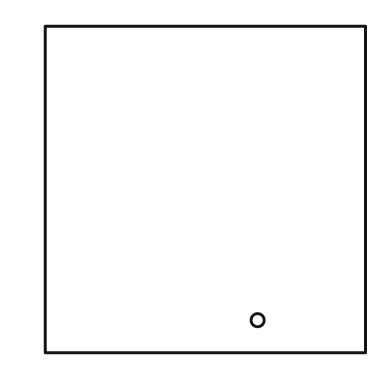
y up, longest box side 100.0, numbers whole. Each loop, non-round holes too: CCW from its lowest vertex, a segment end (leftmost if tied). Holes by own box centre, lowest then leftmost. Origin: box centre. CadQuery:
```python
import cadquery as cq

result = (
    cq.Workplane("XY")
    .moveTo(-49.0, -50.0)
    .lineTo(49.0, -50.0)
    .lineTo(49.0, 50.0)
    .lineTo(-49.0, 50.0)
    .close()
    .moveTo(16.0, -40.0)
    .circle(2.0)
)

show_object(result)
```